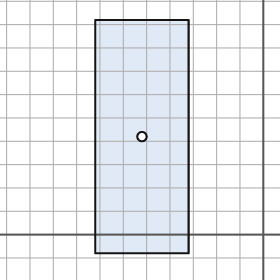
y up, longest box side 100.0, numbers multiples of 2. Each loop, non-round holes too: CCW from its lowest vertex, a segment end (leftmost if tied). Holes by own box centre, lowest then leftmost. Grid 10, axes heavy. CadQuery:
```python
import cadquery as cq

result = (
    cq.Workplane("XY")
    .moveTo(-72.0, -8.0)
    .lineTo(-32.0, -8.0)
    .lineTo(-32.0, 92.0)
    .lineTo(-72.0, 92.0)
    .close()
    .moveTo(-52.0, 42.0)
    .circle(2.0)
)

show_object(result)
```